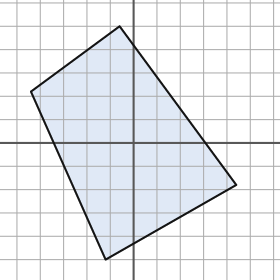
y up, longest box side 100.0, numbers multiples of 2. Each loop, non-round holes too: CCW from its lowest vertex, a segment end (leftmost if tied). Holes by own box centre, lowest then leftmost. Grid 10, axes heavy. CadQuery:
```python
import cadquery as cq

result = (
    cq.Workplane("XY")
    .moveTo(-12.0, -50.0)
    .lineTo(44.0, -18.0)
    .lineTo(-6.0, 50.0)
    .lineTo(-44.0, 22.0)
    .close()
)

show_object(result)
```